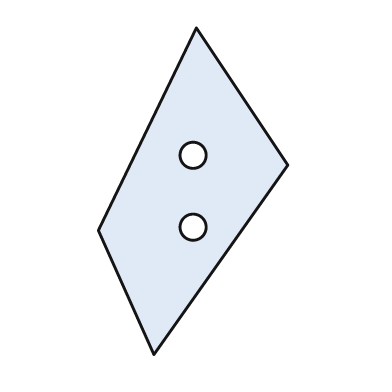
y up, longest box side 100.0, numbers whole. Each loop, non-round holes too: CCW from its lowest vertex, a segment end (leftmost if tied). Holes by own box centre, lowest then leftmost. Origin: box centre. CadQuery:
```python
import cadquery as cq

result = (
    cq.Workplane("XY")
    .moveTo(-12.0, -50.0)
    .lineTo(29.0, 8.0)
    .lineTo(1.0, 50.0)
    .lineTo(-29.0, -12.0)
    .close()
    .moveTo(0.0, -11.0)
    .circle(4.0)
    .moveTo(0.0, 11.0)
    .circle(4.0)
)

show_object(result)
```